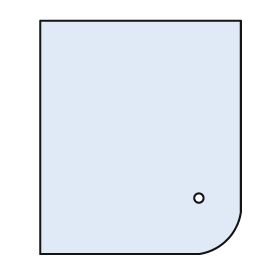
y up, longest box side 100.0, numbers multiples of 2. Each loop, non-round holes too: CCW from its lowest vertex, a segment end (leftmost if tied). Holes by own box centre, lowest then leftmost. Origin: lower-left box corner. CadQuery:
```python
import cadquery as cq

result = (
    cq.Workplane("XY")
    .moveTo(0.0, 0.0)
    .lineTo(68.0, 0.0)
    .threePointArc((80.0, 6.0), (86.0, 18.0))
    .lineTo(86.0, 100.0)
    .lineTo(0.0, 100.0)
    .close()
    .moveTo(68.0, 24.0)
    .circle(2.0)
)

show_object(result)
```